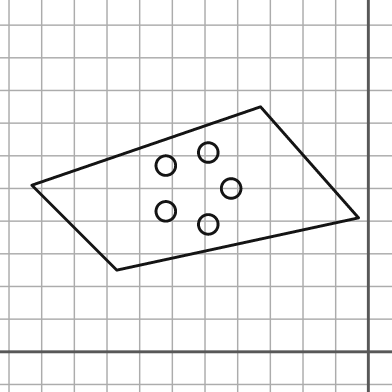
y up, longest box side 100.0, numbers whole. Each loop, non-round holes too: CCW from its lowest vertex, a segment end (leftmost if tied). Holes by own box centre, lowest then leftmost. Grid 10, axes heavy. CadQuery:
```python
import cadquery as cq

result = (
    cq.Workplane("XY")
    .moveTo(-77.0, 25.0)
    .lineTo(-3.0, 41.0)
    .lineTo(-33.0, 75.0)
    .lineTo(-103.0, 51.0)
    .close()
    .moveTo(-49.0, 39.0)
    .circle(3.0)
    .moveTo(-62.0, 43.0)
    .circle(3.0)
    .moveTo(-42.0, 50.0)
    .circle(3.0)
    .moveTo(-62.0, 57.0)
    .circle(3.0)
    .moveTo(-49.0, 61.0)
    .circle(3.0)
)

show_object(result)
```